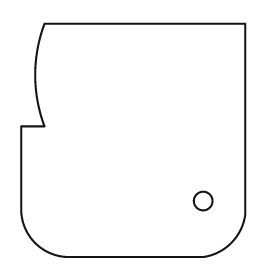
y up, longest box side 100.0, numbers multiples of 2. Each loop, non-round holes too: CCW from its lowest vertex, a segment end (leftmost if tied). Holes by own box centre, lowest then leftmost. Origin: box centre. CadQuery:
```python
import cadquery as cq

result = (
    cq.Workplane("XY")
    .moveTo(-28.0, -50.0)
    .lineTo(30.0, -50.0)
    .threePointArc((42.0, -44.0), (48.0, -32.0))
    .lineTo(48.0, 50.0)
    .lineTo(-38.0, 50.0)
    .threePointArc((-42.0, 28.0), (-38.0, 6.0))
    .lineTo(-48.0, 6.0)
    .lineTo(-48.0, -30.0)
    .threePointArc((-42.0, -44.0), (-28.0, -50.0))
    .close()
    .moveTo(30.0, -26.0)
    .circle(4.0)
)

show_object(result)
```